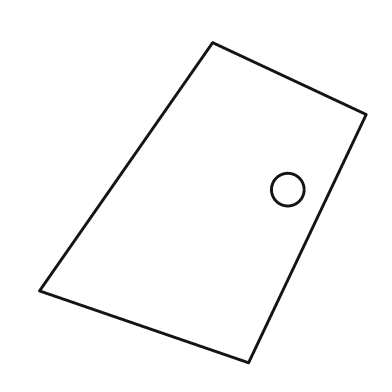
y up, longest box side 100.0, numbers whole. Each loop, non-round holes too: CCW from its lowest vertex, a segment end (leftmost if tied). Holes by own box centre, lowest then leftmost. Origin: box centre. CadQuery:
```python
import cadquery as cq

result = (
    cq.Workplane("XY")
    .moveTo(14.0, -49.0)
    .lineTo(50.0, 27.0)
    .lineTo(3.0, 49.0)
    .lineTo(-50.0, -27.0)
    .close()
    .moveTo(26.0, 4.0)
    .circle(5.0)
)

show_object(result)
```